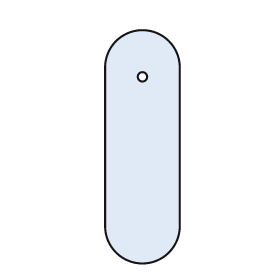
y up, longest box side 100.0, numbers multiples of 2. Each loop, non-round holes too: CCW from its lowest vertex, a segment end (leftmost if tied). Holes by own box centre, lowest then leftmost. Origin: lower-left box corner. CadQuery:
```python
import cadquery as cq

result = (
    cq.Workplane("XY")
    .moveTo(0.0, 16.0)
    .threePointArc((16.0, 0.0), (32.0, 16.0))
    .lineTo(32.0, 84.0)
    .threePointArc((16.0, 100.0), (0.0, 84.0))
    .close()
    .moveTo(16.0, 80.0)
    .circle(2.0)
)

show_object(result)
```